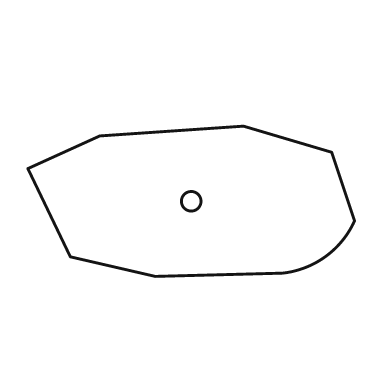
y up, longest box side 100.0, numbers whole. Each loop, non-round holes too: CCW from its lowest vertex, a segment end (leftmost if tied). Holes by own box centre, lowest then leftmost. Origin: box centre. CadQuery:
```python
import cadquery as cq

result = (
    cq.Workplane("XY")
    .moveTo(-11.0, -23.0)
    .lineTo(28.0, -22.0)
    .threePointArc((41.0, -17.0), (50.0, -6.0))
    .lineTo(43.0, 15.0)
    .lineTo(16.0, 23.0)
    .lineTo(-28.0, 20.0)
    .lineTo(-50.0, 10.0)
    .lineTo(-37.0, -17.0)
    .close()
    .moveTo(0.0, 0.0)
    .circle(3.0)
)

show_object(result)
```